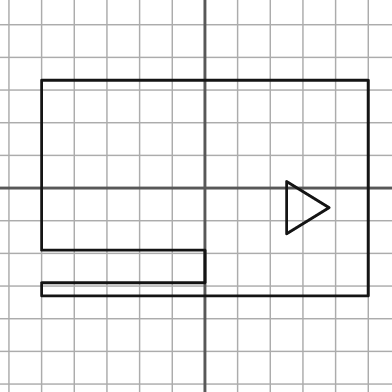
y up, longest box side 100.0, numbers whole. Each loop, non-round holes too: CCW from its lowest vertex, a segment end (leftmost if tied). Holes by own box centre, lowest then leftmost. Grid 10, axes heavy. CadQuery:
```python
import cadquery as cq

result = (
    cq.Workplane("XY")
    .moveTo(-50.0, -33.0)
    .lineTo(50.0, -33.0)
    .lineTo(50.0, 33.0)
    .lineTo(-50.0, 33.0)
    .lineTo(-50.0, -19.0)
    .lineTo(0.0, -19.0)
    .lineTo(0.0, -29.0)
    .lineTo(-50.0, -29.0)
    .close()
    .moveTo(25.0, -14.0)
    .lineTo(38.0, -6.0)
    .lineTo(25.0, 2.0)
    .close()
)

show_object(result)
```